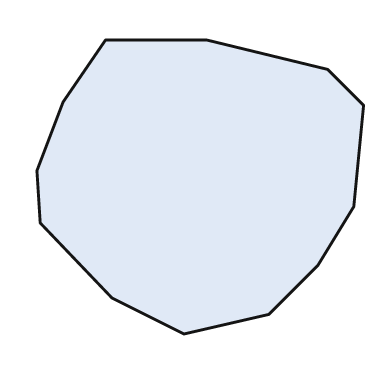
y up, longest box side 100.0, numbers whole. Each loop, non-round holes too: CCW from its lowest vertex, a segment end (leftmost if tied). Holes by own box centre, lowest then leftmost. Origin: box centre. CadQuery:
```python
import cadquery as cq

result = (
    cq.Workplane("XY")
    .moveTo(-5.0, -45.0)
    .lineTo(21.0, -39.0)
    .lineTo(36.0, -24.0)
    .lineTo(47.0, -6.0)
    .lineTo(50.0, 25.0)
    .lineTo(39.0, 36.0)
    .lineTo(2.0, 45.0)
    .lineTo(-29.0, 45.0)
    .lineTo(-42.0, 26.0)
    .lineTo(-50.0, 5.0)
    .lineTo(-49.0, -11.0)
    .lineTo(-27.0, -34.0)
    .close()
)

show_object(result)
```